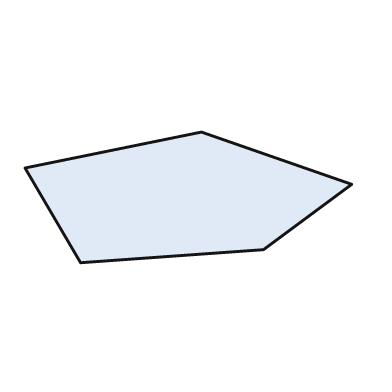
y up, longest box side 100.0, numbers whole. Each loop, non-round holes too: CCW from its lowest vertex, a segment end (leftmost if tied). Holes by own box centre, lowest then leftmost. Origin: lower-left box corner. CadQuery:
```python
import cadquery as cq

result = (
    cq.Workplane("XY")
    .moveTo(17.0, 0.0)
    .lineTo(73.0, 4.0)
    .lineTo(100.0, 24.0)
    .lineTo(54.0, 40.0)
    .lineTo(0.0, 29.0)
    .close()
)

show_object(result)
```